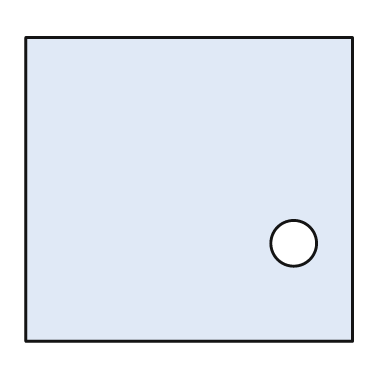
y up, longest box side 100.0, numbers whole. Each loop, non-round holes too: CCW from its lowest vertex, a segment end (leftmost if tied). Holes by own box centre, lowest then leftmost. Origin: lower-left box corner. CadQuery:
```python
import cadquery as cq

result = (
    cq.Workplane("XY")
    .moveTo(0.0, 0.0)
    .lineTo(100.0, 0.0)
    .lineTo(100.0, 93.0)
    .lineTo(0.0, 93.0)
    .close()
    .moveTo(82.0, 30.0)
    .circle(7.0)
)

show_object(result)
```